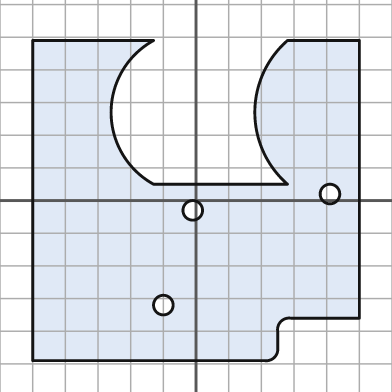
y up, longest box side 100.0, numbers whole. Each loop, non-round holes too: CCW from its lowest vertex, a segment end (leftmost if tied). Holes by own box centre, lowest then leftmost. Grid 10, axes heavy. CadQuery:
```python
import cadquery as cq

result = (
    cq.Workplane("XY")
    .moveTo(-50.0, -49.0)
    .lineTo(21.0, -49.0)
    .threePointArc((24.0, -48.0), (25.0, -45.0))
    .lineTo(25.0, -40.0)
    .threePointArc((26.0, -37.0), (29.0, -36.0))
    .lineTo(50.0, -36.0)
    .lineTo(50.0, 49.0)
    .lineTo(28.0, 49.0)
    .threePointArc((18.0, 27.0), (28.0, 5.0))
    .lineTo(-13.0, 5.0)
    .threePointArc((-26.0, 27.0), (-13.0, 49.0))
    .lineTo(-50.0, 49.0)
    .close()
    .moveTo(-10.0, -32.0)
    .circle(3.0)
    .moveTo(-1.0, -3.0)
    .circle(3.0)
    .moveTo(41.0, 2.0)
    .circle(3.0)
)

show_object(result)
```